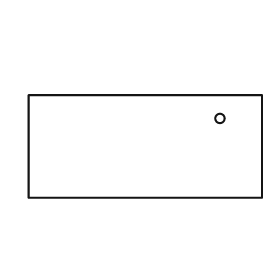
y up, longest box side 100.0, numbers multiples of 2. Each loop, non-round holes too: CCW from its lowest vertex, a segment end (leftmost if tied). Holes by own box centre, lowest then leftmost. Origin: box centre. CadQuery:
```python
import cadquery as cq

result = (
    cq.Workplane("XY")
    .moveTo(-50.0, -22.0)
    .lineTo(50.0, -22.0)
    .lineTo(50.0, 22.0)
    .lineTo(-50.0, 22.0)
    .close()
    .moveTo(32.0, 12.0)
    .circle(2.0)
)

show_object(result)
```